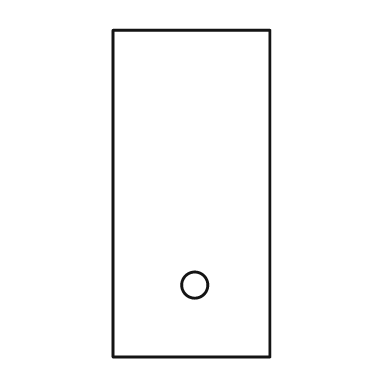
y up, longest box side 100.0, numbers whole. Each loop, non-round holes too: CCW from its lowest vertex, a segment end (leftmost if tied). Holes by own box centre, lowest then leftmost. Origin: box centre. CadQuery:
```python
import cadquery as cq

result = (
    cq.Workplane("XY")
    .moveTo(-24.0, -50.0)
    .lineTo(24.0, -50.0)
    .lineTo(24.0, 50.0)
    .lineTo(-24.0, 50.0)
    .close()
    .moveTo(1.0, -28.0)
    .circle(4.0)
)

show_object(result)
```